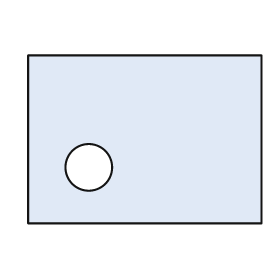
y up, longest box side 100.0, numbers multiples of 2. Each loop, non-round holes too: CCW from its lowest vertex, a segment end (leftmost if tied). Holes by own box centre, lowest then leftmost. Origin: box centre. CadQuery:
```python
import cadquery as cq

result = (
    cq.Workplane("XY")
    .moveTo(-50.0, -36.0)
    .lineTo(50.0, -36.0)
    .lineTo(50.0, 36.0)
    .lineTo(-50.0, 36.0)
    .close()
    .moveTo(-24.0, -12.0)
    .circle(10.0)
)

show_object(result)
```